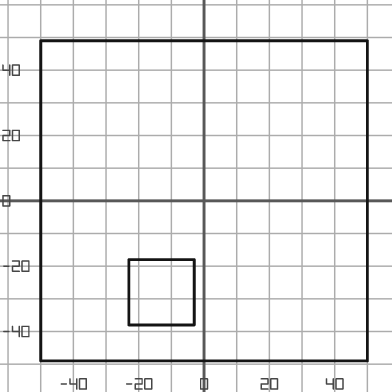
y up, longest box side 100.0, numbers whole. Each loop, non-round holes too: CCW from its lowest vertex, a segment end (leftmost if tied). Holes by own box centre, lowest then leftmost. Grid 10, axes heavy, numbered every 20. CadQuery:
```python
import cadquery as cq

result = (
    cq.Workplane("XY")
    .moveTo(-50.0, -49.0)
    .lineTo(50.0, -49.0)
    .lineTo(50.0, 49.0)
    .lineTo(-50.0, 49.0)
    .close()
    .moveTo(-23.0, -38.0)
    .lineTo(-3.0, -38.0)
    .lineTo(-3.0, -18.0)
    .lineTo(-23.0, -18.0)
    .close()
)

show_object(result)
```